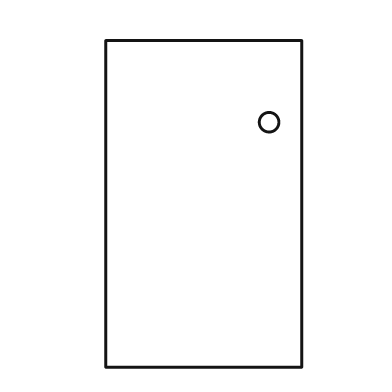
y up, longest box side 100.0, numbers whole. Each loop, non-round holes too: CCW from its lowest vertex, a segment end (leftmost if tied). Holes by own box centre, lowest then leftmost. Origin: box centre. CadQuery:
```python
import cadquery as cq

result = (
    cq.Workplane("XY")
    .moveTo(-30.0, -50.0)
    .lineTo(30.0, -50.0)
    .lineTo(30.0, 50.0)
    .lineTo(-30.0, 50.0)
    .close()
    .moveTo(20.0, 25.0)
    .circle(3.0)
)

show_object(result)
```